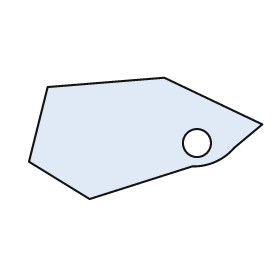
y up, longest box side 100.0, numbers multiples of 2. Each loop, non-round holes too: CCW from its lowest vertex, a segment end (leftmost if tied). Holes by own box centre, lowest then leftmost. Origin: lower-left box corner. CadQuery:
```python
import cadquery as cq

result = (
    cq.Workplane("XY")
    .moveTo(26.0, 0.0)
    .lineTo(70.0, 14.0)
    .threePointArc((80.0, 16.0), (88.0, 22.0))
    .lineTo(100.0, 32.0)
    .lineTo(58.0, 52.0)
    .lineTo(8.0, 48.0)
    .lineTo(0.0, 16.0)
    .close()
    .moveTo(72.0, 24.0)
    .circle(6.0)
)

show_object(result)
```